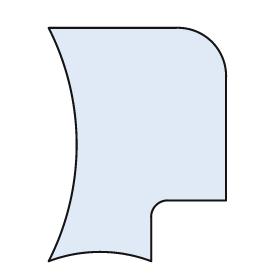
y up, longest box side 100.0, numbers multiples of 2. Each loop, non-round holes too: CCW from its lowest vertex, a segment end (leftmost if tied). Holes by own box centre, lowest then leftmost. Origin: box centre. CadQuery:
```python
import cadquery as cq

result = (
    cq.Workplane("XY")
    .moveTo(-38.0, -50.0)
    .threePointArc((-16.0, -46.0), (6.0, -50.0))
    .lineTo(6.0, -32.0)
    .threePointArc((8.0, -26.0), (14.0, -24.0))
    .lineTo(38.0, -24.0)
    .lineTo(38.0, 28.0)
    .threePointArc((32.0, 44.0), (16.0, 50.0))
    .lineTo(-38.0, 50.0)
    .threePointArc((-26.0, 0.0), (-38.0, -50.0))
    .close()
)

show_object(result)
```